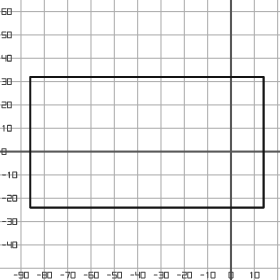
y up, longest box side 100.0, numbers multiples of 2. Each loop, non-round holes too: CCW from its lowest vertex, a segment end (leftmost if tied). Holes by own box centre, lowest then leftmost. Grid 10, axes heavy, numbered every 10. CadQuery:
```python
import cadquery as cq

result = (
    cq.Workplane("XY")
    .moveTo(-86.0, -24.0)
    .lineTo(14.0, -24.0)
    .lineTo(14.0, 32.0)
    .lineTo(-86.0, 32.0)
    .close()
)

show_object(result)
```